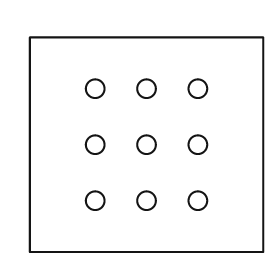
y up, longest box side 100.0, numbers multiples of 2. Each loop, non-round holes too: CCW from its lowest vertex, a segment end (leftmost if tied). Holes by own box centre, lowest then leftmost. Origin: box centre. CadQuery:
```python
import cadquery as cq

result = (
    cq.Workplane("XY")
    .moveTo(-50.0, -46.0)
    .lineTo(50.0, -46.0)
    .lineTo(50.0, 46.0)
    .lineTo(-50.0, 46.0)
    .close()
    .moveTo(-22.0, -24.0)
    .circle(4.0)
    .moveTo(0.0, -24.0)
    .circle(4.0)
    .moveTo(22.0, -24.0)
    .circle(4.0)
    .moveTo(-22.0, 0.0)
    .circle(4.0)
    .moveTo(0.0, 0.0)
    .circle(4.0)
    .moveTo(22.0, 0.0)
    .circle(4.0)
    .moveTo(-22.0, 24.0)
    .circle(4.0)
    .moveTo(0.0, 24.0)
    .circle(4.0)
    .moveTo(22.0, 24.0)
    .circle(4.0)
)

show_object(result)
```